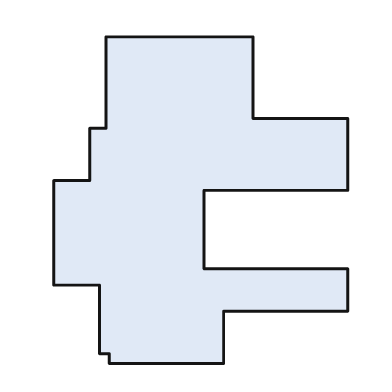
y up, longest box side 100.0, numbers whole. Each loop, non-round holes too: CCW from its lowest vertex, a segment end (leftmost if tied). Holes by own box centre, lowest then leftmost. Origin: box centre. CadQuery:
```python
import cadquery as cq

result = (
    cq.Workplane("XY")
    .moveTo(-28.0, -50.0)
    .lineTo(7.0, -50.0)
    .lineTo(7.0, -34.0)
    .lineTo(45.0, -34.0)
    .lineTo(45.0, -21.0)
    .lineTo(1.0, -21.0)
    .lineTo(1.0, 3.0)
    .lineTo(45.0, 3.0)
    .lineTo(45.0, 25.0)
    .lineTo(16.0, 25.0)
    .lineTo(16.0, 50.0)
    .lineTo(-29.0, 50.0)
    .lineTo(-29.0, 22.0)
    .lineTo(-34.0, 22.0)
    .lineTo(-34.0, 6.0)
    .lineTo(-45.0, 6.0)
    .lineTo(-45.0, -26.0)
    .lineTo(-31.0, -26.0)
    .lineTo(-31.0, -47.0)
    .lineTo(-28.0, -47.0)
    .close()
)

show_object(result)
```